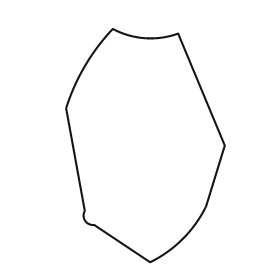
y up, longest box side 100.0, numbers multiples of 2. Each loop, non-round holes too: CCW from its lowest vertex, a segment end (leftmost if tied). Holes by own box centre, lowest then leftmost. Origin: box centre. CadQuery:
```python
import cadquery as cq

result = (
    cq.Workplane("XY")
    .moveTo(2.0, -50.0)
    .threePointArc((16.0, -40.0), (26.0, -26.0))
    .lineTo(34.0, 0.0)
    .lineTo(14.0, 48.0)
    .threePointArc((0.0, 46.0), (-14.0, 50.0))
    .threePointArc((-26.0, 34.0), (-34.0, 16.0))
    .lineTo(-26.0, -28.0)
    .threePointArc((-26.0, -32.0), (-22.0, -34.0))
    .close()
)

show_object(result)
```